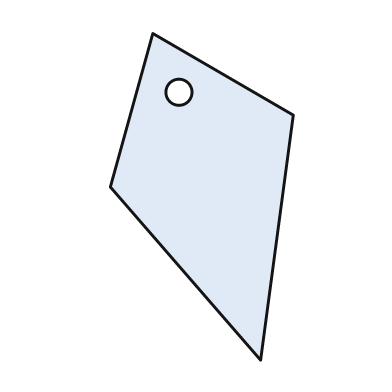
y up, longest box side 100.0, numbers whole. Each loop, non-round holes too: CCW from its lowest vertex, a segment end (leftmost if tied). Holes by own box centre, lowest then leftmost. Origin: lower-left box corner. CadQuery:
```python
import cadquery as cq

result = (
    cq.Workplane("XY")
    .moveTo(46.0, 0.0)
    .lineTo(56.0, 75.0)
    .lineTo(13.0, 100.0)
    .lineTo(0.0, 53.0)
    .close()
    .moveTo(21.0, 82.0)
    .circle(4.0)
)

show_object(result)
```